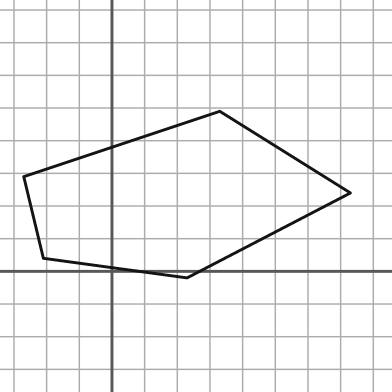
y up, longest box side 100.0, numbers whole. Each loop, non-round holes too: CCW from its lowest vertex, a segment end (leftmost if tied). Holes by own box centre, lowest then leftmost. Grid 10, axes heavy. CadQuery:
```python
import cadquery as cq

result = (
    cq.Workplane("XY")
    .moveTo(23.0, -2.0)
    .lineTo(73.0, 24.0)
    .lineTo(33.0, 49.0)
    .lineTo(-27.0, 29.0)
    .lineTo(-21.0, 4.0)
    .close()
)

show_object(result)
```